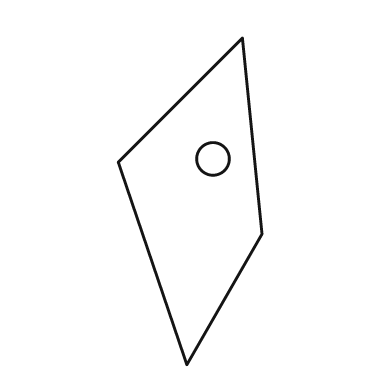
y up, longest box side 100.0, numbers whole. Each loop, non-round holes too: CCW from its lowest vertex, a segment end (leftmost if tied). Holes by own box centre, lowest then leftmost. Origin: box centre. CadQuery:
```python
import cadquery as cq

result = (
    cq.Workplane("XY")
    .moveTo(-1.0, -50.0)
    .lineTo(22.0, -10.0)
    .lineTo(16.0, 50.0)
    .lineTo(-22.0, 12.0)
    .close()
    .moveTo(7.0, 13.0)
    .circle(5.0)
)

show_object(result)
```